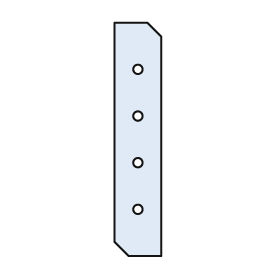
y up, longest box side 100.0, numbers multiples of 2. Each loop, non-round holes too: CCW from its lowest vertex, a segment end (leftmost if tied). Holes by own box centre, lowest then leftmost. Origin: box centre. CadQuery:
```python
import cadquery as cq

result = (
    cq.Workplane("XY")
    .moveTo(-4.0, -50.0)
    .lineTo(10.0, -50.0)
    .lineTo(10.0, 44.0)
    .lineTo(4.0, 50.0)
    .lineTo(-10.0, 50.0)
    .lineTo(-10.0, -44.0)
    .close()
    .moveTo(0.0, -30.0)
    .circle(2.0)
    .moveTo(0.0, -10.0)
    .circle(2.0)
    .moveTo(0.0, 10.0)
    .circle(2.0)
    .moveTo(0.0, 30.0)
    .circle(2.0)
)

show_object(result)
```